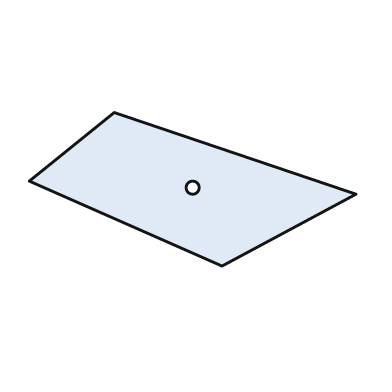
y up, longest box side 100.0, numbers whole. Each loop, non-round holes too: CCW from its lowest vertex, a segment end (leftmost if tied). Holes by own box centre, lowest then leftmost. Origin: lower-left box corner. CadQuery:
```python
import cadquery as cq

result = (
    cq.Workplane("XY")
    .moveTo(59.0, 0.0)
    .lineTo(100.0, 22.0)
    .lineTo(26.0, 47.0)
    .lineTo(0.0, 26.0)
    .close()
    .moveTo(50.0, 24.0)
    .circle(2.0)
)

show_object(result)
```